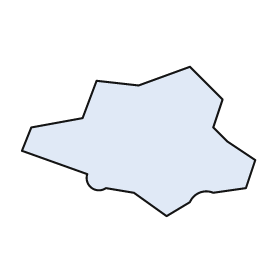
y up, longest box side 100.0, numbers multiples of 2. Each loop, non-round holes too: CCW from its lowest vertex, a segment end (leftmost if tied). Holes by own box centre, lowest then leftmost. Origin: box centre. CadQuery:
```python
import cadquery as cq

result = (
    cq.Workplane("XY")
    .moveTo(12.0, -32.0)
    .lineTo(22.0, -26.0)
    .threePointArc((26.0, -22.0), (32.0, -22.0))
    .lineTo(46.0, -20.0)
    .lineTo(50.0, -8.0)
    .lineTo(38.0, 0.0)
    .lineTo(32.0, 6.0)
    .lineTo(36.0, 18.0)
    .lineTo(22.0, 32.0)
    .lineTo(0.0, 24.0)
    .lineTo(-18.0, 26.0)
    .lineTo(-24.0, 10.0)
    .lineTo(-46.0, 6.0)
    .lineTo(-50.0, -4.0)
    .lineTo(-22.0, -14.0)
    .threePointArc((-20.0, -20.0), (-14.0, -20.0))
    .lineTo(-2.0, -22.0)
    .close()
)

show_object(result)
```